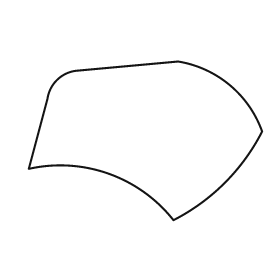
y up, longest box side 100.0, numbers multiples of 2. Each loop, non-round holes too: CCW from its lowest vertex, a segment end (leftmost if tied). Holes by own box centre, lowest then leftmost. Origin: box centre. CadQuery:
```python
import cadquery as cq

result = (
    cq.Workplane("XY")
    .moveTo(12.0, -34.0)
    .threePointArc((34.0, -18.0), (50.0, 4.0))
    .threePointArc((36.0, 24.0), (14.0, 34.0))
    .lineTo(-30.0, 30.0)
    .threePointArc((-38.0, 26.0), (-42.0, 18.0))
    .lineTo(-50.0, -12.0)
    .threePointArc((-16.0, -14.0), (12.0, -34.0))
    .close()
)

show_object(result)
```